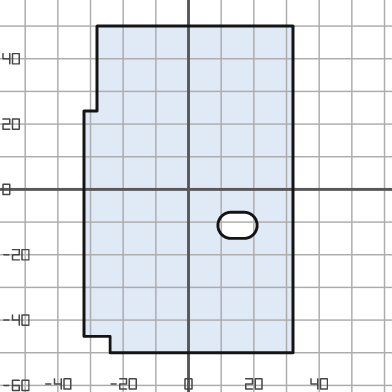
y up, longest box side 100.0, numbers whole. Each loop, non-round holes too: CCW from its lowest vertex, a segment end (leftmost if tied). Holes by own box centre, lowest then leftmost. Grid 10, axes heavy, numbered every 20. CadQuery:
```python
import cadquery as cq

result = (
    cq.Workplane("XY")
    .moveTo(-24.0, -50.0)
    .lineTo(32.0, -50.0)
    .lineTo(32.0, 50.0)
    .lineTo(-28.0, 50.0)
    .lineTo(-28.0, 24.0)
    .lineTo(-32.0, 24.0)
    .lineTo(-32.0, -45.0)
    .lineTo(-24.0, -45.0)
    .close()
    .moveTo(13.0, -15.0)
    .lineTo(17.0, -15.0)
    .threePointArc((21.0, -11.0), (17.0, -7.0))
    .lineTo(13.0, -7.0)
    .threePointArc((9.0, -11.0), (13.0, -15.0))
    .close()
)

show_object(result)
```